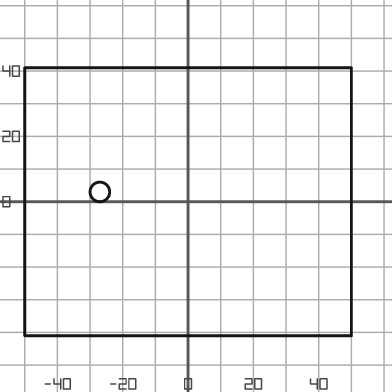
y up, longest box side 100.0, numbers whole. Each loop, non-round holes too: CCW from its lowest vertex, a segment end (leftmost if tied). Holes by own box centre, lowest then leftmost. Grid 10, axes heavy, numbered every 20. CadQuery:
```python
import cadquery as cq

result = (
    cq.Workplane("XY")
    .moveTo(-50.0, -41.0)
    .lineTo(50.0, -41.0)
    .lineTo(50.0, 41.0)
    .lineTo(-50.0, 41.0)
    .close()
    .moveTo(-27.0, 3.0)
    .circle(3.0)
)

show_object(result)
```